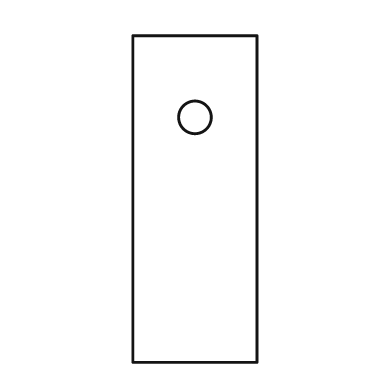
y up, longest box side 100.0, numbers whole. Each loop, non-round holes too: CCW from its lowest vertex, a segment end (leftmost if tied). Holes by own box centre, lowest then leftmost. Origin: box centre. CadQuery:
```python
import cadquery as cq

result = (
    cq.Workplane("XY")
    .moveTo(-19.0, -50.0)
    .lineTo(19.0, -50.0)
    .lineTo(19.0, 50.0)
    .lineTo(-19.0, 50.0)
    .close()
    .moveTo(0.0, 25.0)
    .circle(5.0)
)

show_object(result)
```